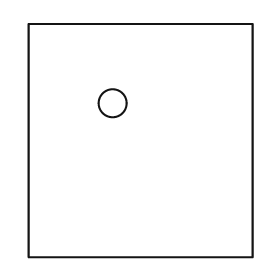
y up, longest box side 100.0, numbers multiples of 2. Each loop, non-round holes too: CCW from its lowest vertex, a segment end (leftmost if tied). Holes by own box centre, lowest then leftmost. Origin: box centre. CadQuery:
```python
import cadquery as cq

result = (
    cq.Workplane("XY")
    .moveTo(-48.0, -50.0)
    .lineTo(48.0, -50.0)
    .lineTo(48.0, 50.0)
    .lineTo(-48.0, 50.0)
    .close()
    .moveTo(-12.0, 16.0)
    .circle(6.0)
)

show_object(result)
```